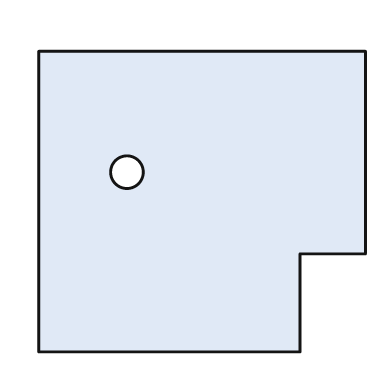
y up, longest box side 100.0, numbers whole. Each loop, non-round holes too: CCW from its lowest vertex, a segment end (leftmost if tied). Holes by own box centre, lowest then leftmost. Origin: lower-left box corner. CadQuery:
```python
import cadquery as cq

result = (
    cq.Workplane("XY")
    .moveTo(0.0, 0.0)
    .lineTo(80.0, 0.0)
    .lineTo(80.0, 30.0)
    .lineTo(100.0, 30.0)
    .lineTo(100.0, 92.0)
    .lineTo(0.0, 92.0)
    .close()
    .moveTo(27.0, 55.0)
    .circle(5.0)
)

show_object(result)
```